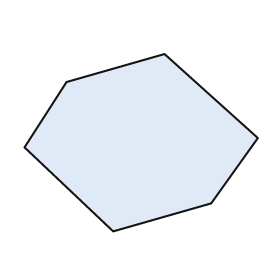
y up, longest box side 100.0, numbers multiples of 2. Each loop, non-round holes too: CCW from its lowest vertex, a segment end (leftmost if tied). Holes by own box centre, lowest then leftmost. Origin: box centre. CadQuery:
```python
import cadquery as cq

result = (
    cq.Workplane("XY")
    .moveTo(-12.0, -38.0)
    .lineTo(30.0, -26.0)
    .lineTo(50.0, 2.0)
    .lineTo(10.0, 38.0)
    .lineTo(-32.0, 26.0)
    .lineTo(-50.0, -2.0)
    .close()
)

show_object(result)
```